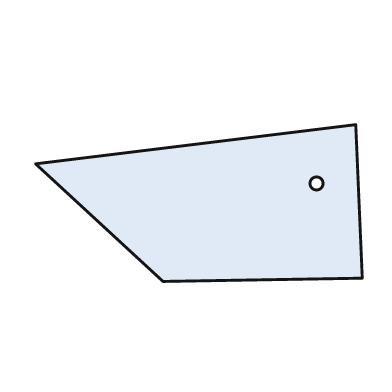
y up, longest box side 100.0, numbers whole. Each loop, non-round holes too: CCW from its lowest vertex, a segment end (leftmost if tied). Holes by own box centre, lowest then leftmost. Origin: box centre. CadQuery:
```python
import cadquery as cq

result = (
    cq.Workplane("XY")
    .moveTo(-11.0, -24.0)
    .lineTo(50.0, -23.0)
    .lineTo(48.0, 24.0)
    .lineTo(-50.0, 12.0)
    .close()
    .moveTo(36.0, 6.0)
    .circle(2.0)
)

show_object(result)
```